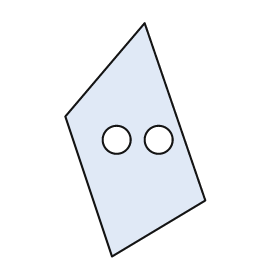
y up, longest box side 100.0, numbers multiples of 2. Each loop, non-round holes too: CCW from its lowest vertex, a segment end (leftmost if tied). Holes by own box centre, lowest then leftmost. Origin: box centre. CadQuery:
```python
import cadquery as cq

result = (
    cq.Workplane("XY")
    .moveTo(-10.0, -50.0)
    .lineTo(30.0, -26.0)
    .lineTo(4.0, 50.0)
    .lineTo(-30.0, 10.0)
    .close()
    .moveTo(-8.0, 0.0)
    .circle(6.0)
    .moveTo(10.0, 0.0)
    .circle(6.0)
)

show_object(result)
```